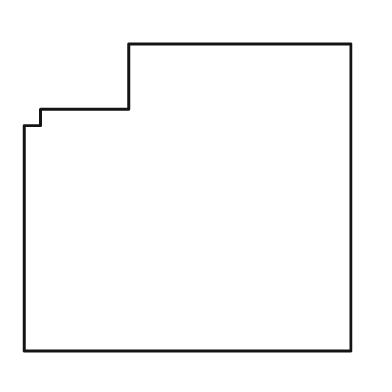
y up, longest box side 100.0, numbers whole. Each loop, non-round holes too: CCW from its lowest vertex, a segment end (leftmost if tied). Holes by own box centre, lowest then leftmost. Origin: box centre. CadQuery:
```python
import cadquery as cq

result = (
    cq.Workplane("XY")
    .moveTo(-50.0, -47.0)
    .lineTo(50.0, -47.0)
    .lineTo(50.0, 47.0)
    .lineTo(-18.0, 47.0)
    .lineTo(-18.0, 27.0)
    .lineTo(-45.0, 27.0)
    .lineTo(-45.0, 22.0)
    .lineTo(-50.0, 22.0)
    .close()
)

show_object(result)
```